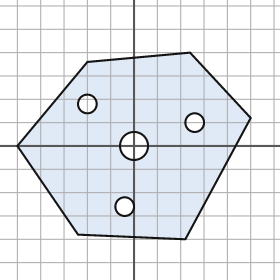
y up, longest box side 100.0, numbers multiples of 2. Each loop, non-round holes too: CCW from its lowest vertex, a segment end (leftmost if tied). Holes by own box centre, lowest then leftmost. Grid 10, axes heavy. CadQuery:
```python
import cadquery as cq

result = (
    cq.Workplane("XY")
    .moveTo(22.0, -40.0)
    .lineTo(50.0, 12.0)
    .lineTo(24.0, 40.0)
    .lineTo(-20.0, 36.0)
    .lineTo(-50.0, 0.0)
    .lineTo(-24.0, -38.0)
    .close()
    .moveTo(-4.0, -26.0)
    .circle(4.0)
    .moveTo(0.0, 0.0)
    .circle(6.0)
    .moveTo(26.0, 10.0)
    .circle(4.0)
    .moveTo(-20.0, 18.0)
    .circle(4.0)
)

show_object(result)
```